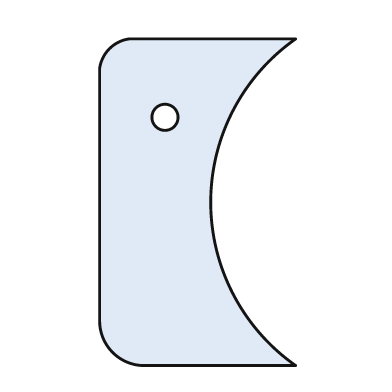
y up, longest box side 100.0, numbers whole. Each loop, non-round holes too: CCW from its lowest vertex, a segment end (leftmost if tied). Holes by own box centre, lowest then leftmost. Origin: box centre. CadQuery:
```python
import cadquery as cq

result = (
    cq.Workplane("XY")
    .moveTo(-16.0, -50.0)
    .lineTo(30.0, -50.0)
    .threePointArc((4.0, 0.0), (30.0, 50.0))
    .lineTo(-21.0, 50.0)
    .threePointArc((-27.0, 47.0), (-30.0, 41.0))
    .lineTo(-30.0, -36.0)
    .threePointArc((-26.0, -46.0), (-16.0, -50.0))
    .close()
    .moveTo(-10.0, 26.0)
    .circle(4.0)
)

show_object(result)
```